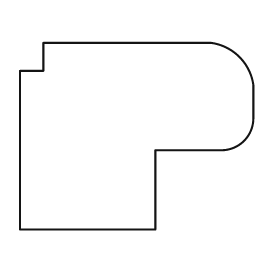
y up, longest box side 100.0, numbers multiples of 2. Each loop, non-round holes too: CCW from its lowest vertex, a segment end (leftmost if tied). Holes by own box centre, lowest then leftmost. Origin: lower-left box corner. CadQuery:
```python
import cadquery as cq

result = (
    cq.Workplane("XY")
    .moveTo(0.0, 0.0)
    .lineTo(58.0, 0.0)
    .lineTo(58.0, 34.0)
    .lineTo(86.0, 34.0)
    .threePointArc((96.0, 38.0), (100.0, 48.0))
    .lineTo(100.0, 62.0)
    .threePointArc((94.0, 74.0), (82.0, 80.0))
    .lineTo(10.0, 80.0)
    .lineTo(10.0, 68.0)
    .lineTo(0.0, 68.0)
    .close()
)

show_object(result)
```